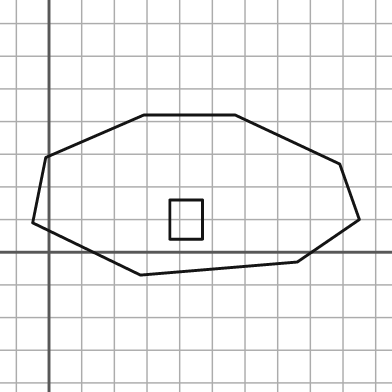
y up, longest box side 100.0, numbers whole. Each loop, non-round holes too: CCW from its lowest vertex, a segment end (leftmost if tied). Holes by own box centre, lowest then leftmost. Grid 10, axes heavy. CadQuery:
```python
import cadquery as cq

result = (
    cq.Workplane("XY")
    .moveTo(28.0, -7.0)
    .lineTo(76.0, -3.0)
    .lineTo(95.0, 10.0)
    .lineTo(89.0, 27.0)
    .lineTo(57.0, 42.0)
    .lineTo(29.0, 42.0)
    .lineTo(-1.0, 29.0)
    .lineTo(-5.0, 9.0)
    .close()
    .moveTo(37.0, 4.0)
    .lineTo(47.0, 4.0)
    .lineTo(47.0, 16.0)
    .lineTo(37.0, 16.0)
    .close()
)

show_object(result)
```